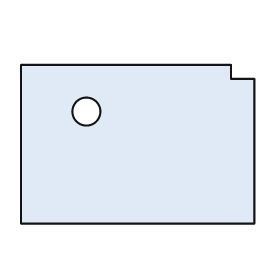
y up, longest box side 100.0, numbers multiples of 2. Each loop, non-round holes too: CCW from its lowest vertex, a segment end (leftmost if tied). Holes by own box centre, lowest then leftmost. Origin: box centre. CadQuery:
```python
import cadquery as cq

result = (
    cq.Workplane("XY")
    .moveTo(-50.0, -34.0)
    .lineTo(50.0, -34.0)
    .lineTo(50.0, 28.0)
    .lineTo(40.0, 28.0)
    .lineTo(40.0, 34.0)
    .lineTo(-50.0, 34.0)
    .close()
    .moveTo(-22.0, 14.0)
    .circle(6.0)
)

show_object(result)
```